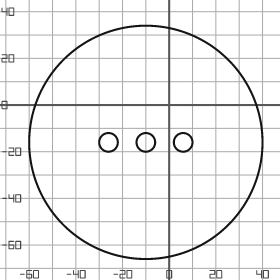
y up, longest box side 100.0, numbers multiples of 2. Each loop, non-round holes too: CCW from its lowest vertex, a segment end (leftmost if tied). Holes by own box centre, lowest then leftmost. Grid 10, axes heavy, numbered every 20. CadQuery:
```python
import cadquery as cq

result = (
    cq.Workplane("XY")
    .moveTo(-10.0, -16.0)
    .circle(50.0)
    .moveTo(-26.0, -16.0)
    .circle(4.0)
    .moveTo(-10.0, -16.0)
    .circle(4.0)
    .moveTo(6.0, -16.0)
    .circle(4.0)
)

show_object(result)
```